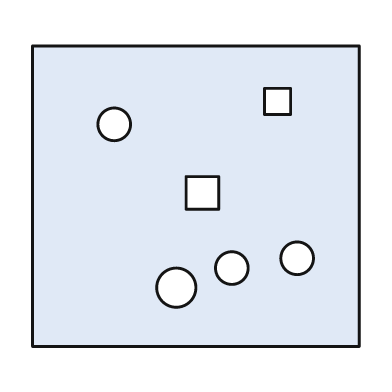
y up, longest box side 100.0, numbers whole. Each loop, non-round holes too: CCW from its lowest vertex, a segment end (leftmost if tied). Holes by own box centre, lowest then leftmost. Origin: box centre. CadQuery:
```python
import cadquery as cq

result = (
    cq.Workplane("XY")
    .moveTo(-50.0, -46.0)
    .lineTo(50.0, -46.0)
    .lineTo(50.0, 46.0)
    .lineTo(-50.0, 46.0)
    .close()
    .moveTo(-6.0, -28.0)
    .circle(6.0)
    .moveTo(11.0, -22.0)
    .circle(5.0)
    .moveTo(31.0, -19.0)
    .circle(5.0)
    .moveTo(-3.0, -4.0)
    .lineTo(7.0, -4.0)
    .lineTo(7.0, 6.0)
    .lineTo(-3.0, 6.0)
    .close()
    .moveTo(-25.0, 22.0)
    .circle(5.0)
    .moveTo(21.0, 25.0)
    .lineTo(29.0, 25.0)
    .lineTo(29.0, 33.0)
    .lineTo(21.0, 33.0)
    .close()
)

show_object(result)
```